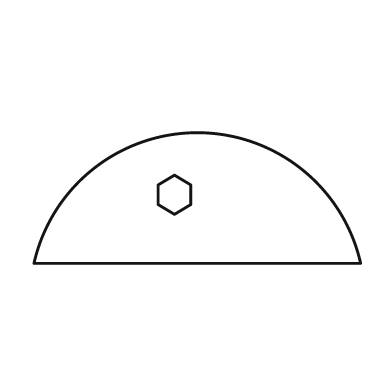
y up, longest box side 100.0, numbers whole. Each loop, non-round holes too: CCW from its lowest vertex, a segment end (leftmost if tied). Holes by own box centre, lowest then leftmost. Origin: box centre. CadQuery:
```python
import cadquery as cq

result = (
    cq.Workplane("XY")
    .moveTo(-50.0, -20.0)
    .lineTo(50.0, -20.0)
    .threePointArc((0.0, 20.0), (-50.0, -20.0))
    .close()
    .moveTo(-7.0, -5.0)
    .lineTo(-2.0, -2.0)
    .lineTo(-2.0, 4.0)
    .lineTo(-7.0, 7.0)
    .lineTo(-12.0, 4.0)
    .lineTo(-12.0, -2.0)
    .close()
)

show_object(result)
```